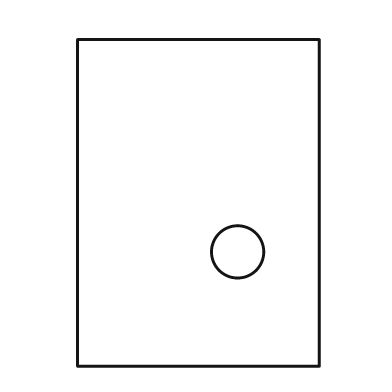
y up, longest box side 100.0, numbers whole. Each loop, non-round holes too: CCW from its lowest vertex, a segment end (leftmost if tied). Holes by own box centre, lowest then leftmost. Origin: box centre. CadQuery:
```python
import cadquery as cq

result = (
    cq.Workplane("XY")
    .moveTo(-37.0, -50.0)
    .lineTo(37.0, -50.0)
    .lineTo(37.0, 50.0)
    .lineTo(-37.0, 50.0)
    .close()
    .moveTo(12.0, -15.0)
    .circle(8.0)
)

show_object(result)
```